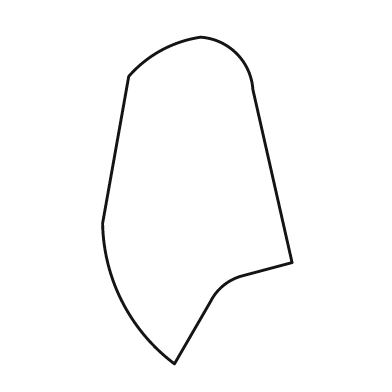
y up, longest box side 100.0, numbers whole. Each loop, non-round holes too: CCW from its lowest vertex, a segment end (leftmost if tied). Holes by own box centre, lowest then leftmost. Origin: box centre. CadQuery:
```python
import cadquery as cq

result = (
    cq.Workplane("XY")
    .moveTo(-7.0, -50.0)
    .lineTo(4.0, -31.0)
    .threePointArc((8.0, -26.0), (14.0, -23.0))
    .lineTo(29.0, -19.0)
    .lineTo(17.0, 34.0)
    .threePointArc((12.0, 45.0), (1.0, 50.0))
    .threePointArc((-11.0, 46.0), (-21.0, 38.0))
    .lineTo(-29.0, -7.0)
    .threePointArc((-23.0, -31.0), (-7.0, -50.0))
    .close()
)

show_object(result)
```